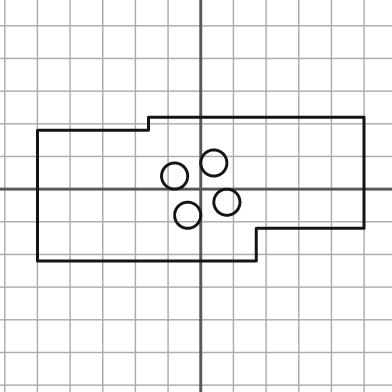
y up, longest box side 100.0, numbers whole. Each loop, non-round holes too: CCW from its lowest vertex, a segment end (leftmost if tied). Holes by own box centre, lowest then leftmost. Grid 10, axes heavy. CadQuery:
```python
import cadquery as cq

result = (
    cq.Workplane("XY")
    .moveTo(-50.0, -22.0)
    .lineTo(17.0, -22.0)
    .lineTo(17.0, -12.0)
    .lineTo(50.0, -12.0)
    .lineTo(50.0, 22.0)
    .lineTo(-16.0, 22.0)
    .lineTo(-16.0, 18.0)
    .lineTo(-50.0, 18.0)
    .close()
    .moveTo(-4.0, -8.0)
    .circle(4.0)
    .moveTo(8.0, -4.0)
    .circle(4.0)
    .moveTo(-8.0, 4.0)
    .circle(4.0)
    .moveTo(4.0, 8.0)
    .circle(4.0)
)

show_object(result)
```